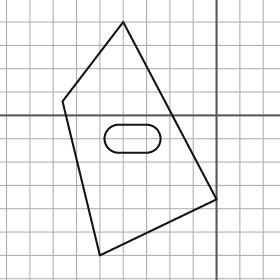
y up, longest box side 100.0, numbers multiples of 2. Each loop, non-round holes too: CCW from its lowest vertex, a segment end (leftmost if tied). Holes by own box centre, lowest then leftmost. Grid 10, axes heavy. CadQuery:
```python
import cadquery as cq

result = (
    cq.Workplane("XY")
    .moveTo(-50.0, -60.0)
    .lineTo(0.0, -36.0)
    .lineTo(-40.0, 40.0)
    .lineTo(-66.0, 6.0)
    .close()
    .moveTo(-42.0, -16.0)
    .lineTo(-30.0, -16.0)
    .threePointArc((-24.0, -10.0), (-30.0, -4.0))
    .lineTo(-42.0, -4.0)
    .threePointArc((-48.0, -10.0), (-42.0, -16.0))
    .close()
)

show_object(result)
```